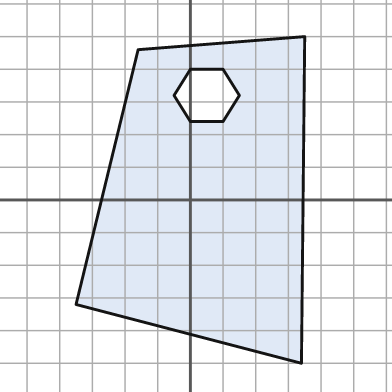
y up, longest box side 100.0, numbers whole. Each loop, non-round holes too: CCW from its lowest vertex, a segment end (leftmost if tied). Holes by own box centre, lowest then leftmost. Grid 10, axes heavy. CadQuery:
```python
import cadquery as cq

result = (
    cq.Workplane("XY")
    .moveTo(34.0, -50.0)
    .lineTo(35.0, 50.0)
    .lineTo(-16.0, 46.0)
    .lineTo(-35.0, -32.0)
    .close()
    .moveTo(0.0, 24.0)
    .lineTo(10.0, 24.0)
    .lineTo(15.0, 32.0)
    .lineTo(10.0, 40.0)
    .lineTo(0.0, 40.0)
    .lineTo(-5.0, 32.0)
    .close()
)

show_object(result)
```